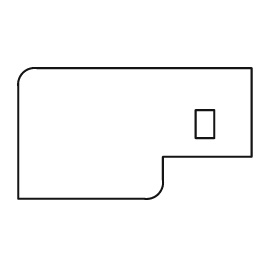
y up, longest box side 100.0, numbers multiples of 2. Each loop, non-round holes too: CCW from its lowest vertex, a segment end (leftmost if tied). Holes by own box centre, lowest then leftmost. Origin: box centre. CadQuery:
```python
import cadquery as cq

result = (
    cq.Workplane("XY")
    .moveTo(-50.0, -28.0)
    .lineTo(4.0, -28.0)
    .threePointArc((10.0, -26.0), (12.0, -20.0))
    .lineTo(12.0, -10.0)
    .lineTo(50.0, -10.0)
    .lineTo(50.0, 28.0)
    .lineTo(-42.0, 28.0)
    .threePointArc((-48.0, 26.0), (-50.0, 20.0))
    .close()
    .moveTo(26.0, -2.0)
    .lineTo(34.0, -2.0)
    .lineTo(34.0, 10.0)
    .lineTo(26.0, 10.0)
    .close()
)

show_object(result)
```